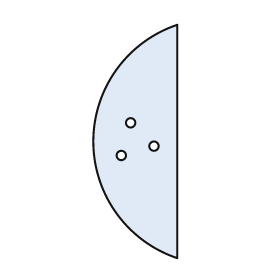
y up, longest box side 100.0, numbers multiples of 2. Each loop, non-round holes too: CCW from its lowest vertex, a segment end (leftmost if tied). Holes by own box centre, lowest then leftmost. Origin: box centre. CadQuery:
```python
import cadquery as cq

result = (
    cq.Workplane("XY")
    .moveTo(18.0, -50.0)
    .lineTo(18.0, 50.0)
    .threePointArc((-18.0, 0.0), (18.0, -50.0))
    .close()
    .moveTo(-6.0, -6.0)
    .circle(2.0)
    .moveTo(8.0, -2.0)
    .circle(2.0)
    .moveTo(-2.0, 8.0)
    .circle(2.0)
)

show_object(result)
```